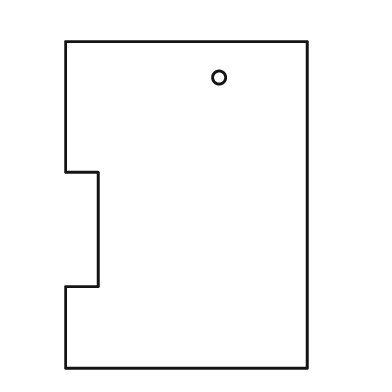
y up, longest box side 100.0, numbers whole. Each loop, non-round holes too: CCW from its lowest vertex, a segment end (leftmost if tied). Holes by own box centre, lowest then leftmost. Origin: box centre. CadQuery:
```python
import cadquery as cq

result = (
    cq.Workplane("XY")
    .moveTo(-37.0, -50.0)
    .lineTo(37.0, -50.0)
    .lineTo(37.0, 50.0)
    .lineTo(-37.0, 50.0)
    .lineTo(-37.0, 10.0)
    .lineTo(-27.0, 10.0)
    .lineTo(-27.0, -25.0)
    .lineTo(-37.0, -25.0)
    .close()
    .moveTo(10.0, 39.0)
    .circle(2.0)
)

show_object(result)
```